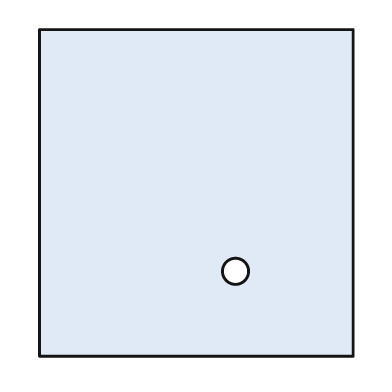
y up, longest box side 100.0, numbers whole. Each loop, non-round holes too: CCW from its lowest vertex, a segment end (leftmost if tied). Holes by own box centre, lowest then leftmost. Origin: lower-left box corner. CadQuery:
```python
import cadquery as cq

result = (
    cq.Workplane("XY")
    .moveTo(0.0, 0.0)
    .lineTo(96.0, 0.0)
    .lineTo(96.0, 100.0)
    .lineTo(0.0, 100.0)
    .close()
    .moveTo(60.0, 26.0)
    .circle(4.0)
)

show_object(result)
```